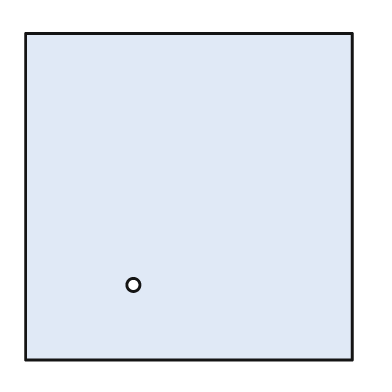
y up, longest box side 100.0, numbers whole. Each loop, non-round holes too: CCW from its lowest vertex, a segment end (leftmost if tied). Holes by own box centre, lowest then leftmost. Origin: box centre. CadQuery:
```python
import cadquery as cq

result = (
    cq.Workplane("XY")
    .moveTo(-50.0, -50.0)
    .lineTo(50.0, -50.0)
    .lineTo(50.0, 50.0)
    .lineTo(-50.0, 50.0)
    .close()
    .moveTo(-17.0, -27.0)
    .circle(2.0)
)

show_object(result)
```